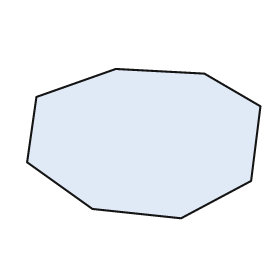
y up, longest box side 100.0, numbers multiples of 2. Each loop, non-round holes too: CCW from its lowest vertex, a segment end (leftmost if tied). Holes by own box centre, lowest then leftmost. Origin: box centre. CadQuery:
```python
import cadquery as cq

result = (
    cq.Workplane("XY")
    .moveTo(16.0, -32.0)
    .lineTo(46.0, -16.0)
    .lineTo(50.0, 16.0)
    .lineTo(26.0, 30.0)
    .lineTo(-12.0, 32.0)
    .lineTo(-46.0, 20.0)
    .lineTo(-50.0, -8.0)
    .lineTo(-22.0, -28.0)
    .close()
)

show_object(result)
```